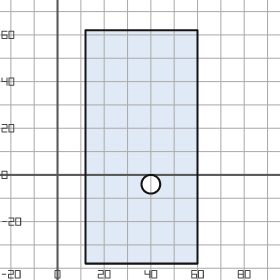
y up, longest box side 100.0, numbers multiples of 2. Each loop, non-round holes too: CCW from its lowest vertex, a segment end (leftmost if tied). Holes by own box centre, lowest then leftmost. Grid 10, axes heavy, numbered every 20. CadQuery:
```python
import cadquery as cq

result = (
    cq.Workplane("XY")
    .moveTo(12.0, -38.0)
    .lineTo(60.0, -38.0)
    .lineTo(60.0, 62.0)
    .lineTo(12.0, 62.0)
    .close()
    .moveTo(40.0, -4.0)
    .circle(4.0)
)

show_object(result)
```